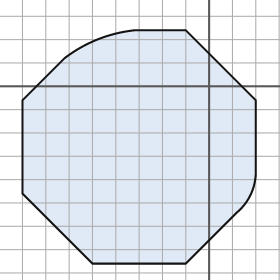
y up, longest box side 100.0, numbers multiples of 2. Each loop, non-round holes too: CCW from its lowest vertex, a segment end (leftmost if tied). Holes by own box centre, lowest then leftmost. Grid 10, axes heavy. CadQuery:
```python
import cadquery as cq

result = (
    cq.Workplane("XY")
    .moveTo(-50.0, -76.0)
    .lineTo(-10.0, -76.0)
    .lineTo(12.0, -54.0)
    .threePointArc((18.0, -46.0), (20.0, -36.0))
    .lineTo(20.0, -6.0)
    .lineTo(-10.0, 24.0)
    .lineTo(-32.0, 24.0)
    .threePointArc((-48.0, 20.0), (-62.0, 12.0))
    .lineTo(-80.0, -6.0)
    .lineTo(-80.0, -46.0)
    .close()
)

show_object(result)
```